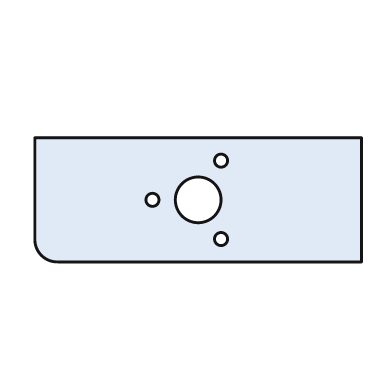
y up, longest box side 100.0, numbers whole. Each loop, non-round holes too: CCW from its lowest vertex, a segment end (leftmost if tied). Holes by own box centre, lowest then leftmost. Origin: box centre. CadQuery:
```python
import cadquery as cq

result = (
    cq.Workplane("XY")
    .moveTo(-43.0, -19.0)
    .lineTo(50.0, -19.0)
    .lineTo(50.0, 19.0)
    .lineTo(-50.0, 19.0)
    .lineTo(-50.0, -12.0)
    .threePointArc((-48.0, -17.0), (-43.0, -19.0))
    .close()
    .moveTo(7.0, -12.0)
    .circle(2.0)
    .moveTo(-14.0, 0.0)
    .circle(2.0)
    .moveTo(0.0, 0.0)
    .circle(7.0)
    .moveTo(7.0, 12.0)
    .circle(2.0)
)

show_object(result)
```